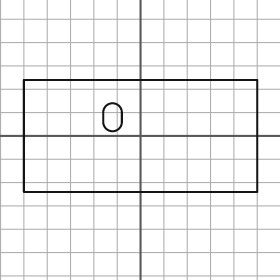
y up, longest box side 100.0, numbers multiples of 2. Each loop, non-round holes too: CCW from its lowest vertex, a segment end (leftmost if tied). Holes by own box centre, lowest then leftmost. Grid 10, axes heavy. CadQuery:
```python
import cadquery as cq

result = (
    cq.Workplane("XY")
    .moveTo(-50.0, -24.0)
    .lineTo(50.0, -24.0)
    .lineTo(50.0, 24.0)
    .lineTo(-50.0, 24.0)
    .close()
    .moveTo(-16.0, 6.0)
    .threePointArc((-12.0, 2.0), (-8.0, 6.0))
    .lineTo(-8.0, 10.0)
    .threePointArc((-12.0, 14.0), (-16.0, 10.0))
    .close()
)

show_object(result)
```